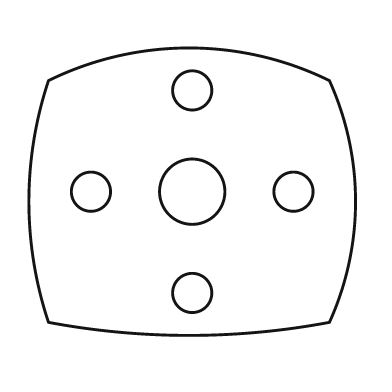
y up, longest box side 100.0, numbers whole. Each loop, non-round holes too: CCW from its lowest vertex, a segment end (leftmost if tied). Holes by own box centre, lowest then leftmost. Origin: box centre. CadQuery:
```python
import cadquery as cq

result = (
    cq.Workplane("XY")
    .moveTo(-44.0, -40.0)
    .threePointArc((-1.0, -44.0), (42.0, -40.0))
    .threePointArc((50.0, -3.0), (42.0, 34.0))
    .threePointArc((-1.0, 44.0), (-44.0, 34.0))
    .threePointArc((-50.0, -3.0), (-44.0, -40.0))
    .close()
    .moveTo(0.0, -31.0)
    .circle(6.0)
    .moveTo(-31.0, 0.0)
    .circle(6.0)
    .moveTo(0.0, 0.0)
    .circle(10.0)
    .moveTo(31.0, 0.0)
    .circle(6.0)
    .moveTo(0.0, 31.0)
    .circle(6.0)
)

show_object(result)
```